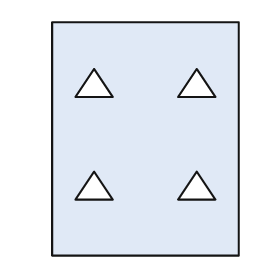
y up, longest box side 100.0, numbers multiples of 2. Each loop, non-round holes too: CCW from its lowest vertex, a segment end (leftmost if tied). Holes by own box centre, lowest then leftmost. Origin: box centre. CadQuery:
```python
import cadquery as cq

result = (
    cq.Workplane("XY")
    .moveTo(-40.0, -50.0)
    .lineTo(40.0, -50.0)
    .lineTo(40.0, 50.0)
    .lineTo(-40.0, 50.0)
    .close()
    .moveTo(-30.0, -26.0)
    .lineTo(-14.0, -26.0)
    .lineTo(-22.0, -14.0)
    .close()
    .moveTo(14.0, -26.0)
    .lineTo(30.0, -26.0)
    .lineTo(22.0, -14.0)
    .close()
    .moveTo(-30.0, 18.0)
    .lineTo(-14.0, 18.0)
    .lineTo(-22.0, 30.0)
    .close()
    .moveTo(14.0, 18.0)
    .lineTo(30.0, 18.0)
    .lineTo(22.0, 30.0)
    .close()
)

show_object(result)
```